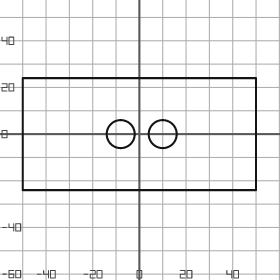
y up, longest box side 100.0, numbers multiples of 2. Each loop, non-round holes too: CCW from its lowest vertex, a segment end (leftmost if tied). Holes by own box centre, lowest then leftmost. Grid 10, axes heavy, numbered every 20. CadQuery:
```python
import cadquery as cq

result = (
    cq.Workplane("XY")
    .moveTo(-50.0, -24.0)
    .lineTo(50.0, -24.0)
    .lineTo(50.0, 24.0)
    .lineTo(-50.0, 24.0)
    .close()
    .moveTo(-8.0, 0.0)
    .circle(6.0)
    .moveTo(10.0, 0.0)
    .circle(6.0)
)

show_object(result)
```